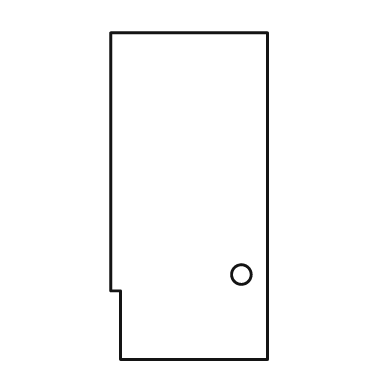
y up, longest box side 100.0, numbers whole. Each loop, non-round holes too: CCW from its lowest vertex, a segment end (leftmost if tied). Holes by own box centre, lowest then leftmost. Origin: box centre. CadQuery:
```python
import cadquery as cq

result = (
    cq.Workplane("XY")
    .moveTo(-21.0, -50.0)
    .lineTo(24.0, -50.0)
    .lineTo(24.0, 50.0)
    .lineTo(-24.0, 50.0)
    .lineTo(-24.0, -29.0)
    .lineTo(-21.0, -29.0)
    .close()
    .moveTo(16.0, -24.0)
    .circle(3.0)
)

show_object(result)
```